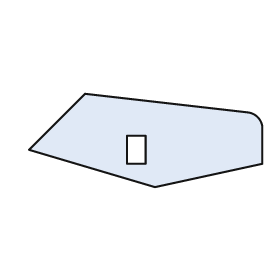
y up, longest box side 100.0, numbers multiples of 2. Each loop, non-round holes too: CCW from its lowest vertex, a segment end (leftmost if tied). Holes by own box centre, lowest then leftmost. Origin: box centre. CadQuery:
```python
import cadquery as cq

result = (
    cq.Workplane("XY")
    .moveTo(4.0, -20.0)
    .lineTo(50.0, -10.0)
    .lineTo(50.0, 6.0)
    .threePointArc((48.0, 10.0), (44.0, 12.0))
    .lineTo(-26.0, 20.0)
    .lineTo(-50.0, -4.0)
    .close()
    .moveTo(-8.0, -10.0)
    .lineTo(0.0, -10.0)
    .lineTo(0.0, 2.0)
    .lineTo(-8.0, 2.0)
    .close()
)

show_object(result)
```